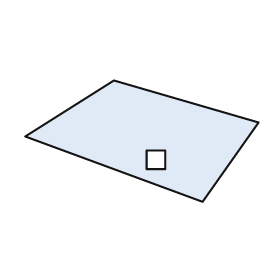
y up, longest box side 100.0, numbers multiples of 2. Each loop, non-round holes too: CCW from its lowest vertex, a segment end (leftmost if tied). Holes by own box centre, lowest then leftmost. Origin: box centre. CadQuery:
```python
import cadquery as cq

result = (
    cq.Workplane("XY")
    .moveTo(26.0, -26.0)
    .lineTo(50.0, 8.0)
    .lineTo(-12.0, 26.0)
    .lineTo(-50.0, 2.0)
    .close()
    .moveTo(2.0, -12.0)
    .lineTo(10.0, -12.0)
    .lineTo(10.0, -4.0)
    .lineTo(2.0, -4.0)
    .close()
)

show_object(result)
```